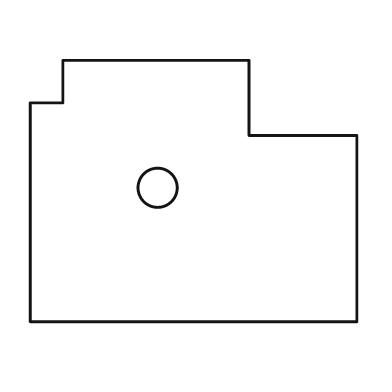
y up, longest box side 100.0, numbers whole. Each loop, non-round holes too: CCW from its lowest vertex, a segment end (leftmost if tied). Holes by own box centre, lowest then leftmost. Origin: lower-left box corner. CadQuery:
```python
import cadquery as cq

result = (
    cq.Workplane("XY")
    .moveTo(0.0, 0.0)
    .lineTo(100.0, 0.0)
    .lineTo(100.0, 57.0)
    .lineTo(67.0, 57.0)
    .lineTo(67.0, 80.0)
    .lineTo(10.0, 80.0)
    .lineTo(10.0, 67.0)
    .lineTo(0.0, 67.0)
    .close()
    .moveTo(39.0, 41.0)
    .circle(6.0)
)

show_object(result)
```